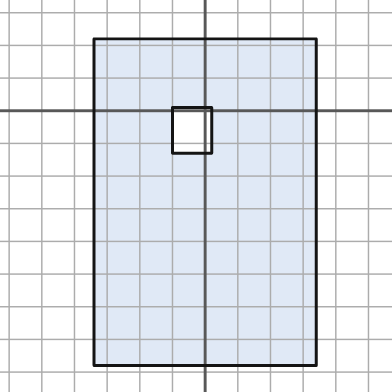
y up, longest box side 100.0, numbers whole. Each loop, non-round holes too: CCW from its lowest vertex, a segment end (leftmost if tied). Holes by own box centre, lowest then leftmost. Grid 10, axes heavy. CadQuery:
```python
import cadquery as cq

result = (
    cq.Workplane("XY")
    .moveTo(-34.0, -78.0)
    .lineTo(34.0, -78.0)
    .lineTo(34.0, 22.0)
    .lineTo(-34.0, 22.0)
    .close()
    .moveTo(-10.0, -13.0)
    .lineTo(2.0, -13.0)
    .lineTo(2.0, 1.0)
    .lineTo(-10.0, 1.0)
    .close()
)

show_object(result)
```